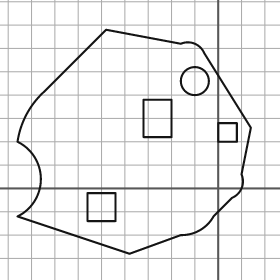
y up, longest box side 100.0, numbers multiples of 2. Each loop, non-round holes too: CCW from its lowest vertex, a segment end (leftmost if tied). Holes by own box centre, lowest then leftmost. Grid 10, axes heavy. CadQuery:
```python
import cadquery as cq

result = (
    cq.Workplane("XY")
    .moveTo(-38.0, -28.0)
    .lineTo(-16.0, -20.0)
    .threePointArc((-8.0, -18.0), (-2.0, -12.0))
    .lineTo(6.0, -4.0)
    .threePointArc((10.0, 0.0), (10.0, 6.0))
    .lineTo(14.0, 26.0)
    .lineTo(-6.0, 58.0)
    .threePointArc((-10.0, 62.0), (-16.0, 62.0))
    .lineTo(-48.0, 68.0)
    .lineTo(-74.0, 42.0)
    .threePointArc((-82.0, 32.0), (-86.0, 20.0))
    .threePointArc((-76.0, 4.0), (-86.0, -12.0))
    .close()
    .moveTo(-56.0, -14.0)
    .lineTo(-44.0, -14.0)
    .lineTo(-44.0, -2.0)
    .lineTo(-56.0, -2.0)
    .close()
    .moveTo(0.0, 20.0)
    .lineTo(8.0, 20.0)
    .lineTo(8.0, 28.0)
    .lineTo(0.0, 28.0)
    .close()
    .moveTo(-32.0, 22.0)
    .lineTo(-20.0, 22.0)
    .lineTo(-20.0, 38.0)
    .lineTo(-32.0, 38.0)
    .close()
    .moveTo(-10.0, 46.0)
    .circle(6.0)
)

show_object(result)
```